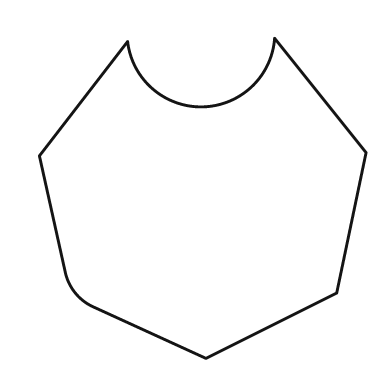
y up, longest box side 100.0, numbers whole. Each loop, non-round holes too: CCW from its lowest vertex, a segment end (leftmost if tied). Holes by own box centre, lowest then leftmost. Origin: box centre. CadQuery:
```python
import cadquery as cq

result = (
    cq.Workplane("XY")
    .moveTo(1.0, -49.0)
    .lineTo(41.0, -29.0)
    .lineTo(50.0, 14.0)
    .lineTo(22.0, 49.0)
    .threePointArc((0.0, 28.0), (-23.0, 48.0))
    .lineTo(-50.0, 13.0)
    .lineTo(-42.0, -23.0)
    .threePointArc((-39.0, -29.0), (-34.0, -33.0))
    .close()
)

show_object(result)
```